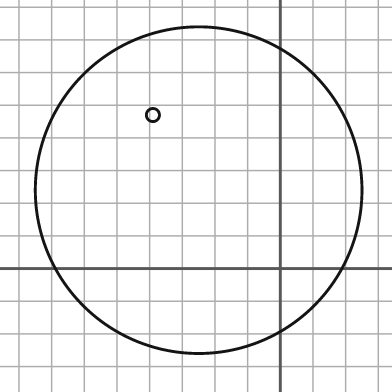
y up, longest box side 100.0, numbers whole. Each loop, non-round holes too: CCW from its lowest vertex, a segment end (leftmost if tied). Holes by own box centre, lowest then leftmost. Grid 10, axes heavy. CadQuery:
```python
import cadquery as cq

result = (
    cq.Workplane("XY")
    .moveTo(-25.0, 24.0)
    .circle(50.0)
    .moveTo(-39.0, 47.0)
    .circle(2.0)
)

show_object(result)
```